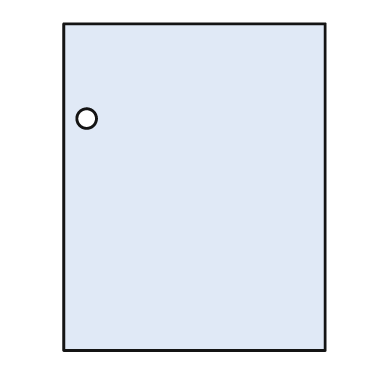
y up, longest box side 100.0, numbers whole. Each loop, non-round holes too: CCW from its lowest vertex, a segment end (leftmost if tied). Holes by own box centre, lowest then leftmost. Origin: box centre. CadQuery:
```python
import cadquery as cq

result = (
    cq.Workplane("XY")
    .moveTo(-40.0, -50.0)
    .lineTo(40.0, -50.0)
    .lineTo(40.0, 50.0)
    .lineTo(-40.0, 50.0)
    .close()
    .moveTo(-33.0, 21.0)
    .circle(3.0)
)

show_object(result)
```